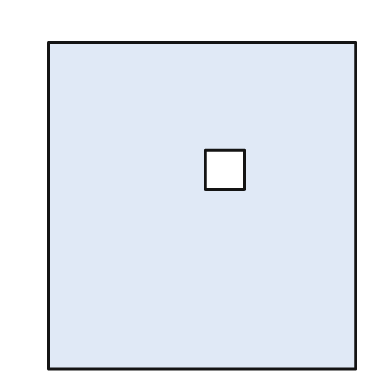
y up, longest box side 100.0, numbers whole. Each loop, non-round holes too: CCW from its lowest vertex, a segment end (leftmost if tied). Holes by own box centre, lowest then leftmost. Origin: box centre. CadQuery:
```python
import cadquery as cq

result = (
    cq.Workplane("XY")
    .moveTo(-47.0, -50.0)
    .lineTo(47.0, -50.0)
    .lineTo(47.0, 50.0)
    .lineTo(-47.0, 50.0)
    .close()
    .moveTo(1.0, 5.0)
    .lineTo(13.0, 5.0)
    .lineTo(13.0, 17.0)
    .lineTo(1.0, 17.0)
    .close()
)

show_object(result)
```